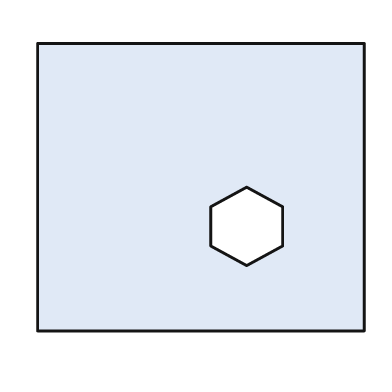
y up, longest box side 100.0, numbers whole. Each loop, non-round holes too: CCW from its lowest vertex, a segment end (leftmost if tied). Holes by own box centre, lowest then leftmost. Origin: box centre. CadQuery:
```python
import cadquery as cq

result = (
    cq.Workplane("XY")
    .moveTo(-50.0, -44.0)
    .lineTo(50.0, -44.0)
    .lineTo(50.0, 44.0)
    .lineTo(-50.0, 44.0)
    .close()
    .moveTo(14.0, -24.0)
    .lineTo(25.0, -18.0)
    .lineTo(25.0, -6.0)
    .lineTo(14.0, 0.0)
    .lineTo(3.0, -6.0)
    .lineTo(3.0, -18.0)
    .close()
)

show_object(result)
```